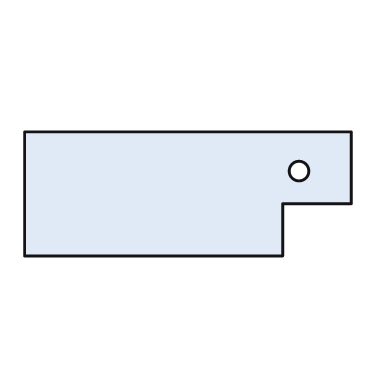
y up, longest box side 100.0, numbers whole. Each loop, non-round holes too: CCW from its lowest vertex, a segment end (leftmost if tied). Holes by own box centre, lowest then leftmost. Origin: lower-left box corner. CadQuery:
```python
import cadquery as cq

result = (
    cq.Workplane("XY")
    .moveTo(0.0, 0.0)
    .lineTo(79.0, 0.0)
    .lineTo(79.0, 16.0)
    .lineTo(100.0, 16.0)
    .lineTo(100.0, 38.0)
    .lineTo(0.0, 38.0)
    .close()
    .moveTo(84.0, 26.0)
    .circle(3.0)
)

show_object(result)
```